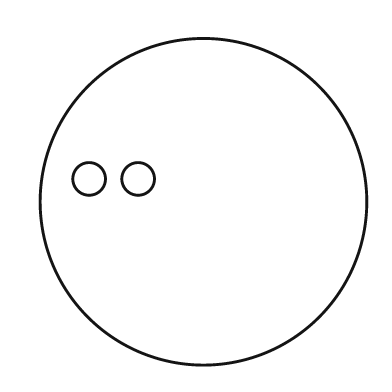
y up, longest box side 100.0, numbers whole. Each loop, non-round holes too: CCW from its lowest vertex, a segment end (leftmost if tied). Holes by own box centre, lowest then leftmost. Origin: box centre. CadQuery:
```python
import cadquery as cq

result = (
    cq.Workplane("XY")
    .moveTo(0.0, 0.0)
    .circle(50.0)
    .moveTo(-35.0, 7.0)
    .circle(5.0)
    .moveTo(-20.0, 7.0)
    .circle(5.0)
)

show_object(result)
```